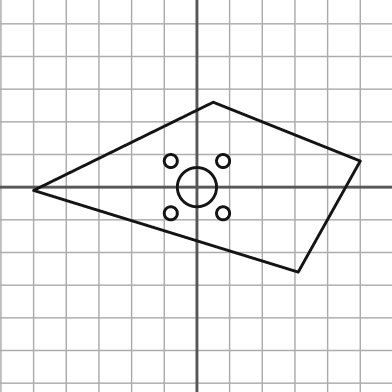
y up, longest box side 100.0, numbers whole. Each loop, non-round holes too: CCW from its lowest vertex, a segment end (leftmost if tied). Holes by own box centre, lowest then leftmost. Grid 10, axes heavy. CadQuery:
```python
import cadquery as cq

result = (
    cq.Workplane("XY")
    .moveTo(31.0, -26.0)
    .lineTo(50.0, 8.0)
    .lineTo(5.0, 26.0)
    .lineTo(-50.0, -1.0)
    .close()
    .moveTo(-8.0, -8.0)
    .circle(2.0)
    .moveTo(8.0, -8.0)
    .circle(2.0)
    .moveTo(0.0, 0.0)
    .circle(6.0)
    .moveTo(-8.0, 8.0)
    .circle(2.0)
    .moveTo(8.0, 8.0)
    .circle(2.0)
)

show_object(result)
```